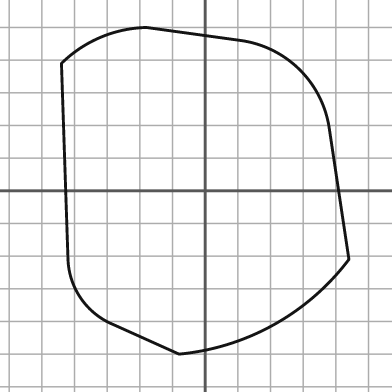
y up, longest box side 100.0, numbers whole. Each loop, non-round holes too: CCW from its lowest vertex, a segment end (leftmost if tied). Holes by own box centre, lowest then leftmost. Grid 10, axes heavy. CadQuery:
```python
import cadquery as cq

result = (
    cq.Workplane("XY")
    .moveTo(-8.0, -50.0)
    .threePointArc((21.0, -41.0), (44.0, -21.0))
    .lineTo(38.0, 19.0)
    .threePointArc((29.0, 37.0), (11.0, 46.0))
    .lineTo(-18.0, 50.0)
    .threePointArc((-32.0, 47.0), (-44.0, 39.0))
    .lineTo(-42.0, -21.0)
    .threePointArc((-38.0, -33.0), (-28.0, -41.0))
    .close()
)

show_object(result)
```